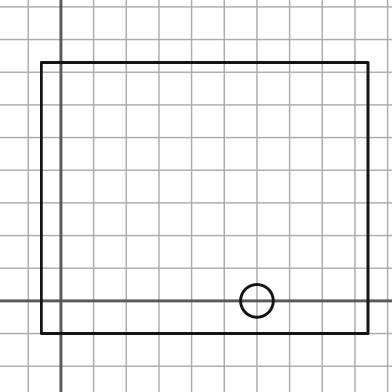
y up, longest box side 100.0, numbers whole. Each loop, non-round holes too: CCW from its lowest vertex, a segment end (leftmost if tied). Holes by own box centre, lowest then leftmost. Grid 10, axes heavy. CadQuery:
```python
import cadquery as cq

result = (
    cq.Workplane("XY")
    .moveTo(-6.0, -10.0)
    .lineTo(94.0, -10.0)
    .lineTo(94.0, 73.0)
    .lineTo(-6.0, 73.0)
    .close()
    .moveTo(60.0, 0.0)
    .circle(5.0)
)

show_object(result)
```